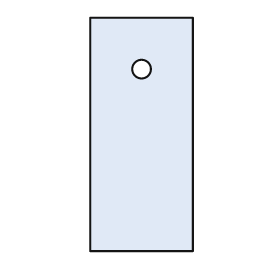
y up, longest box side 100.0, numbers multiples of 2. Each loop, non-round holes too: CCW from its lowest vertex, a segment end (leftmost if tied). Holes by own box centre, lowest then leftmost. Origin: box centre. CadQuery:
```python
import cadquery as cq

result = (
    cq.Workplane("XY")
    .moveTo(-22.0, -50.0)
    .lineTo(22.0, -50.0)
    .lineTo(22.0, 50.0)
    .lineTo(-22.0, 50.0)
    .close()
    .moveTo(0.0, 28.0)
    .circle(4.0)
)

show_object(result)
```